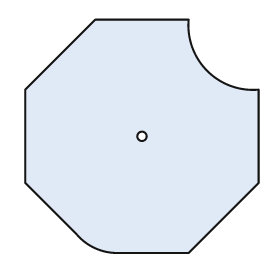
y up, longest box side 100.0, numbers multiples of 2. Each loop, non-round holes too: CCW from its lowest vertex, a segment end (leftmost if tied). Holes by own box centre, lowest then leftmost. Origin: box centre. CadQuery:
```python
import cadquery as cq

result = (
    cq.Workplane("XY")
    .moveTo(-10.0, -50.0)
    .lineTo(20.0, -50.0)
    .lineTo(50.0, -20.0)
    .lineTo(50.0, 20.0)
    .threePointArc((28.0, 28.0), (20.0, 50.0))
    .lineTo(-20.0, 50.0)
    .lineTo(-50.0, 20.0)
    .lineTo(-50.0, -20.0)
    .lineTo(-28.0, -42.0)
    .threePointArc((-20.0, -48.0), (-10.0, -50.0))
    .close()
    .moveTo(0.0, 0.0)
    .circle(2.0)
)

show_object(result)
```